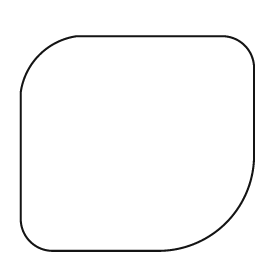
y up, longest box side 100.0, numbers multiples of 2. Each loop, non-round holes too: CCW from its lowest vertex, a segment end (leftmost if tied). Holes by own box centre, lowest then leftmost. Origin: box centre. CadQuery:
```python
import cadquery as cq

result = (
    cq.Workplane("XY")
    .moveTo(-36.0, -46.0)
    .lineTo(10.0, -46.0)
    .threePointArc((38.0, -34.0), (50.0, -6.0))
    .lineTo(50.0, 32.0)
    .threePointArc((46.0, 42.0), (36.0, 46.0))
    .lineTo(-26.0, 46.0)
    .threePointArc((-42.0, 38.0), (-50.0, 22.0))
    .lineTo(-50.0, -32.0)
    .threePointArc((-46.0, -42.0), (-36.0, -46.0))
    .close()
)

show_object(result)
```